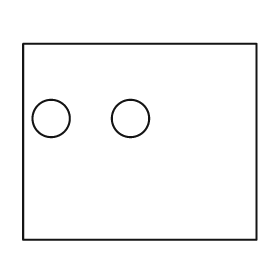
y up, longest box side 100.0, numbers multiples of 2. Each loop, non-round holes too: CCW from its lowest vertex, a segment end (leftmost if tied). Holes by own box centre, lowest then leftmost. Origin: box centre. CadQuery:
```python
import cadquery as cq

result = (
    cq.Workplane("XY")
    .moveTo(-50.0, -42.0)
    .lineTo(50.0, -42.0)
    .lineTo(50.0, 42.0)
    .lineTo(-50.0, 42.0)
    .close()
    .moveTo(-38.0, 10.0)
    .circle(8.0)
    .moveTo(-4.0, 10.0)
    .circle(8.0)
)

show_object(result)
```